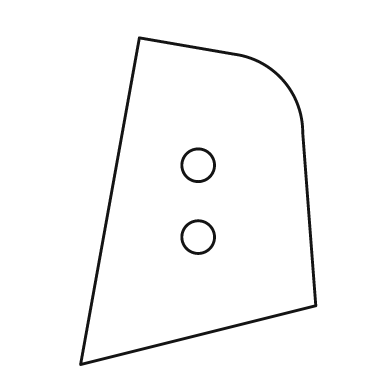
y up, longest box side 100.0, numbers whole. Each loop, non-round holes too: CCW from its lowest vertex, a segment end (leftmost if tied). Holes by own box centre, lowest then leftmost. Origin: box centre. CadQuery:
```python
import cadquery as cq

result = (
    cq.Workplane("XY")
    .moveTo(-36.0, -50.0)
    .lineTo(36.0, -32.0)
    .lineTo(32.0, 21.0)
    .threePointArc((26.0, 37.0), (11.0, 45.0))
    .lineTo(-18.0, 50.0)
    .close()
    .moveTo(0.0, -11.0)
    .circle(5.0)
    .moveTo(0.0, 11.0)
    .circle(5.0)
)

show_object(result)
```